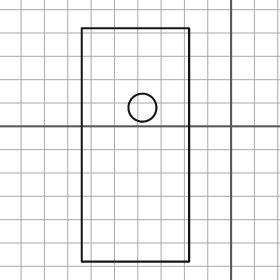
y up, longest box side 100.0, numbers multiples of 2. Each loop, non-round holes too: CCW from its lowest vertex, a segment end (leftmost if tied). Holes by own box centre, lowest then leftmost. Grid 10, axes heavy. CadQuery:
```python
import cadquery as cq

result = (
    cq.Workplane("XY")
    .moveTo(-64.0, -58.0)
    .lineTo(-18.0, -58.0)
    .lineTo(-18.0, 42.0)
    .lineTo(-64.0, 42.0)
    .close()
    .moveTo(-38.0, 8.0)
    .circle(6.0)
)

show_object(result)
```